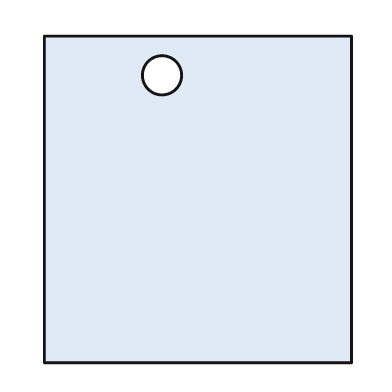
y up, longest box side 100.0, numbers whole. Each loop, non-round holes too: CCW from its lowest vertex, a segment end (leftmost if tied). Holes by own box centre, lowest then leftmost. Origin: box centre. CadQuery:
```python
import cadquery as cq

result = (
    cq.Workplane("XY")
    .moveTo(-47.0, -50.0)
    .lineTo(47.0, -50.0)
    .lineTo(47.0, 50.0)
    .lineTo(-47.0, 50.0)
    .close()
    .moveTo(-11.0, 38.0)
    .circle(6.0)
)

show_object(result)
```